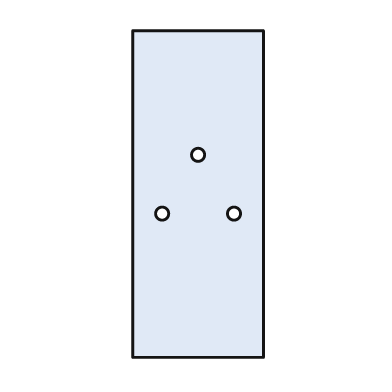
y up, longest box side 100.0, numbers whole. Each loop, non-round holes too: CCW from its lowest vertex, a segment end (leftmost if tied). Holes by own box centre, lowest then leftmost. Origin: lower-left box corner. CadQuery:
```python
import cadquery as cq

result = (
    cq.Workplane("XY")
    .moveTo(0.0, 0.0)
    .lineTo(40.0, 0.0)
    .lineTo(40.0, 100.0)
    .lineTo(0.0, 100.0)
    .close()
    .moveTo(9.0, 44.0)
    .circle(2.0)
    .moveTo(31.0, 44.0)
    .circle(2.0)
    .moveTo(20.0, 62.0)
    .circle(2.0)
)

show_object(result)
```